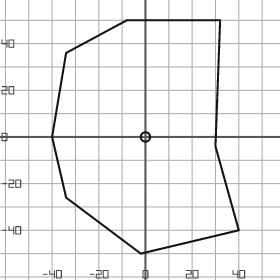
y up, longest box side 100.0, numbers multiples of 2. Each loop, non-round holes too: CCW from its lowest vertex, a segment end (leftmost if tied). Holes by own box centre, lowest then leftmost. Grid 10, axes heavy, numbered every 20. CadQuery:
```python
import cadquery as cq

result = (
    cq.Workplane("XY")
    .moveTo(-2.0, -50.0)
    .lineTo(40.0, -40.0)
    .lineTo(30.0, -4.0)
    .lineTo(32.0, 50.0)
    .lineTo(-8.0, 50.0)
    .lineTo(-34.0, 36.0)
    .lineTo(-40.0, 0.0)
    .lineTo(-34.0, -26.0)
    .close()
    .moveTo(0.0, 0.0)
    .circle(2.0)
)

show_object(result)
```